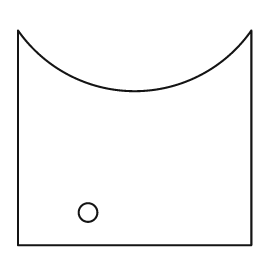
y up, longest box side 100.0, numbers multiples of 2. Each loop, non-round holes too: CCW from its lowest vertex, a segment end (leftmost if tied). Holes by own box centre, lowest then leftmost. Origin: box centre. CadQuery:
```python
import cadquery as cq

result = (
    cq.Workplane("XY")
    .moveTo(-50.0, -46.0)
    .lineTo(50.0, -46.0)
    .lineTo(50.0, 46.0)
    .threePointArc((0.0, 20.0), (-50.0, 46.0))
    .close()
    .moveTo(-20.0, -32.0)
    .circle(4.0)
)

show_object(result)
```